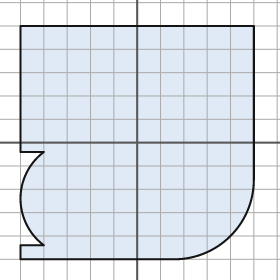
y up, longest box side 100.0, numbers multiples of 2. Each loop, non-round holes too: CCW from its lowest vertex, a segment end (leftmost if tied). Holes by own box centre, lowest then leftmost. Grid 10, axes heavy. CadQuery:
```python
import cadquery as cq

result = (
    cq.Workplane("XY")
    .moveTo(-50.0, -50.0)
    .lineTo(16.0, -50.0)
    .threePointArc((40.0, -40.0), (50.0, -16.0))
    .lineTo(50.0, 50.0)
    .lineTo(-50.0, 50.0)
    .lineTo(-50.0, -4.0)
    .lineTo(-40.0, -4.0)
    .threePointArc((-50.0, -24.0), (-40.0, -44.0))
    .lineTo(-50.0, -44.0)
    .close()
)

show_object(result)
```